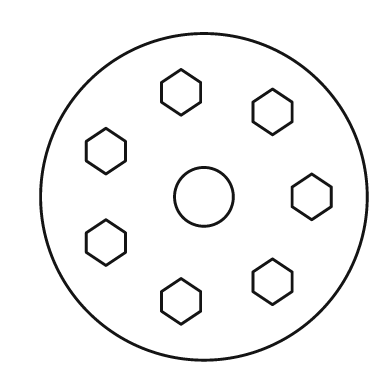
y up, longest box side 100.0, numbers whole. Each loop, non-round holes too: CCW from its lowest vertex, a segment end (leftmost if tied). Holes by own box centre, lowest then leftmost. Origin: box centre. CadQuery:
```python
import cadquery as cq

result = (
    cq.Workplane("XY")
    .moveTo(0.0, 0.0)
    .circle(50.0)
    .moveTo(-7.0, -39.0)
    .lineTo(-1.0, -35.0)
    .lineTo(-1.0, -29.0)
    .lineTo(-7.0, -25.0)
    .lineTo(-13.0, -29.0)
    .lineTo(-13.0, -35.0)
    .close()
    .moveTo(21.0, -33.0)
    .lineTo(27.0, -29.0)
    .lineTo(27.0, -23.0)
    .lineTo(21.0, -19.0)
    .lineTo(15.0, -23.0)
    .lineTo(15.0, -29.0)
    .close()
    .moveTo(-30.0, -21.0)
    .lineTo(-24.0, -17.0)
    .lineTo(-24.0, -11.0)
    .lineTo(-30.0, -7.0)
    .lineTo(-36.0, -11.0)
    .lineTo(-36.0, -17.0)
    .close()
    .moveTo(0.0, 0.0)
    .circle(9.0)
    .moveTo(33.0, -7.0)
    .lineTo(39.0, -3.0)
    .lineTo(39.0, 3.0)
    .lineTo(33.0, 7.0)
    .lineTo(27.0, 3.0)
    .lineTo(27.0, -3.0)
    .close()
    .moveTo(-30.0, 7.0)
    .lineTo(-24.0, 11.0)
    .lineTo(-24.0, 17.0)
    .lineTo(-30.0, 21.0)
    .lineTo(-36.0, 17.0)
    .lineTo(-36.0, 11.0)
    .close()
    .moveTo(21.0, 19.0)
    .lineTo(27.0, 23.0)
    .lineTo(27.0, 29.0)
    .lineTo(21.0, 33.0)
    .lineTo(15.0, 29.0)
    .lineTo(15.0, 23.0)
    .close()
    .moveTo(-7.0, 25.0)
    .lineTo(-1.0, 29.0)
    .lineTo(-1.0, 35.0)
    .lineTo(-7.0, 39.0)
    .lineTo(-13.0, 35.0)
    .lineTo(-13.0, 29.0)
    .close()
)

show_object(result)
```